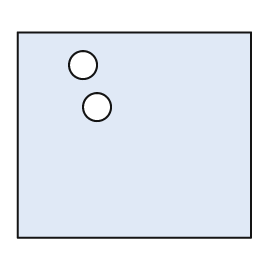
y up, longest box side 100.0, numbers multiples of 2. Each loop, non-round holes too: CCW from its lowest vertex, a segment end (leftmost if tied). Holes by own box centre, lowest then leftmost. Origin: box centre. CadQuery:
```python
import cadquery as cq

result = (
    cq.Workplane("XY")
    .moveTo(-50.0, -44.0)
    .lineTo(50.0, -44.0)
    .lineTo(50.0, 44.0)
    .lineTo(-50.0, 44.0)
    .close()
    .moveTo(-16.0, 12.0)
    .circle(6.0)
    .moveTo(-22.0, 30.0)
    .circle(6.0)
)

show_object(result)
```